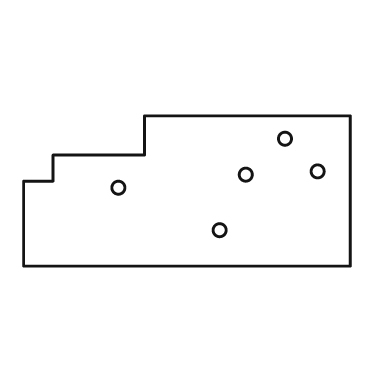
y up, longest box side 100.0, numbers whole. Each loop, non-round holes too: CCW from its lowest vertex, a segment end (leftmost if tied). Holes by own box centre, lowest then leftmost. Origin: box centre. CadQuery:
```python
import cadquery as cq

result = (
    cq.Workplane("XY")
    .moveTo(-50.0, -23.0)
    .lineTo(50.0, -23.0)
    .lineTo(50.0, 23.0)
    .lineTo(-13.0, 23.0)
    .lineTo(-13.0, 11.0)
    .lineTo(-41.0, 11.0)
    .lineTo(-41.0, 3.0)
    .lineTo(-50.0, 3.0)
    .close()
    .moveTo(10.0, -12.0)
    .circle(2.0)
    .moveTo(-21.0, 1.0)
    .circle(2.0)
    .moveTo(18.0, 5.0)
    .circle(2.0)
    .moveTo(40.0, 6.0)
    .circle(2.0)
    .moveTo(30.0, 16.0)
    .circle(2.0)
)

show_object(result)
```